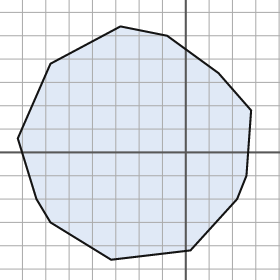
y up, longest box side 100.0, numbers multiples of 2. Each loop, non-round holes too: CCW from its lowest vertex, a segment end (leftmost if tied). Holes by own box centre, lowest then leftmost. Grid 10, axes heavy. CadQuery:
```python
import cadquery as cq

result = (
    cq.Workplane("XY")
    .moveTo(-32.0, -46.0)
    .lineTo(2.0, -42.0)
    .lineTo(22.0, -20.0)
    .lineTo(26.0, -10.0)
    .lineTo(28.0, 18.0)
    .lineTo(14.0, 34.0)
    .lineTo(-8.0, 50.0)
    .lineTo(-28.0, 54.0)
    .lineTo(-58.0, 38.0)
    .lineTo(-72.0, 6.0)
    .lineTo(-64.0, -20.0)
    .lineTo(-58.0, -30.0)
    .close()
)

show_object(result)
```